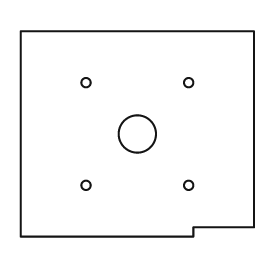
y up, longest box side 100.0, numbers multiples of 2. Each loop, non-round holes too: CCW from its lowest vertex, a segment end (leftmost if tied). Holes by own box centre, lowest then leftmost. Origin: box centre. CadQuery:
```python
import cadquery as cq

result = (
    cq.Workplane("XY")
    .moveTo(-50.0, -44.0)
    .lineTo(24.0, -44.0)
    .lineTo(24.0, -40.0)
    .lineTo(50.0, -40.0)
    .lineTo(50.0, 44.0)
    .lineTo(-50.0, 44.0)
    .close()
    .moveTo(-22.0, -22.0)
    .circle(2.0)
    .moveTo(22.0, -22.0)
    .circle(2.0)
    .moveTo(0.0, 0.0)
    .circle(8.0)
    .moveTo(-22.0, 22.0)
    .circle(2.0)
    .moveTo(22.0, 22.0)
    .circle(2.0)
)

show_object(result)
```